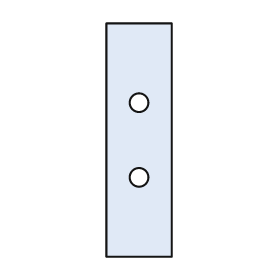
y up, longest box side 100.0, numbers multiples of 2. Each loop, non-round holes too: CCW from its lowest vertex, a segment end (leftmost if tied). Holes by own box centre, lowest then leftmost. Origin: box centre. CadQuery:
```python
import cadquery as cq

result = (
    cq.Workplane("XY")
    .moveTo(-14.0, -50.0)
    .lineTo(14.0, -50.0)
    .lineTo(14.0, 50.0)
    .lineTo(-14.0, 50.0)
    .close()
    .moveTo(0.0, -16.0)
    .circle(4.0)
    .moveTo(0.0, 16.0)
    .circle(4.0)
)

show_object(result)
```